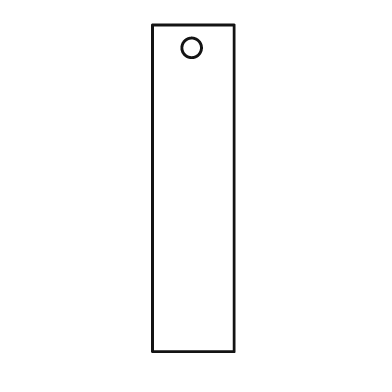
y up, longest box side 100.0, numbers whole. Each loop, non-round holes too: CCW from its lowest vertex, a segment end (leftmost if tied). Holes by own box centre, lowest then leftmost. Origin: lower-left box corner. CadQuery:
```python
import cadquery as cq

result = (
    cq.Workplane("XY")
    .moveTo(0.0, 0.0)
    .lineTo(25.0, 0.0)
    .lineTo(25.0, 100.0)
    .lineTo(0.0, 100.0)
    .close()
    .moveTo(12.0, 93.0)
    .circle(3.0)
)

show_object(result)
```